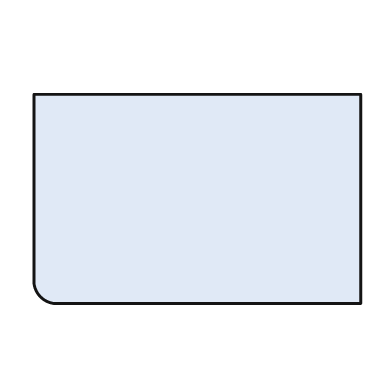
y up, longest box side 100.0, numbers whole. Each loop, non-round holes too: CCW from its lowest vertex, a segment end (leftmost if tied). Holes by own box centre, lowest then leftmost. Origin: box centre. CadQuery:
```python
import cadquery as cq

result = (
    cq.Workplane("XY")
    .moveTo(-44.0, -32.0)
    .lineTo(50.0, -32.0)
    .lineTo(50.0, 32.0)
    .lineTo(-50.0, 32.0)
    .lineTo(-50.0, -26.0)
    .threePointArc((-48.0, -30.0), (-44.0, -32.0))
    .close()
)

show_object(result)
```